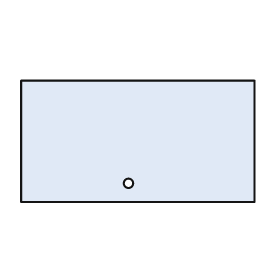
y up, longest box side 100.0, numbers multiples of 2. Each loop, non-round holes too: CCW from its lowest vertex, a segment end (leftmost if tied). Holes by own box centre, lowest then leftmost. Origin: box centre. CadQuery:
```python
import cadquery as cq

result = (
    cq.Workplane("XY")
    .moveTo(-50.0, -26.0)
    .lineTo(50.0, -26.0)
    .lineTo(50.0, 26.0)
    .lineTo(-50.0, 26.0)
    .close()
    .moveTo(-4.0, -18.0)
    .circle(2.0)
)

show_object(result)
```